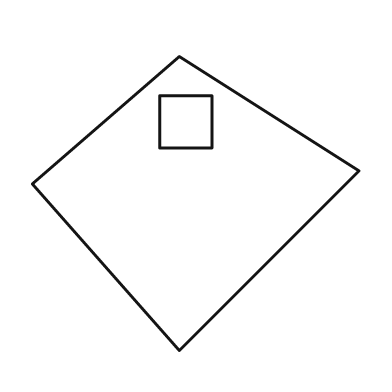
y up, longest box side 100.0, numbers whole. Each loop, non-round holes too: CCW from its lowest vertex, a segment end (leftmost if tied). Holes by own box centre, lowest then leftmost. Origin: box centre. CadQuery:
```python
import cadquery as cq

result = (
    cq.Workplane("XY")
    .moveTo(-5.0, -45.0)
    .lineTo(50.0, 10.0)
    .lineTo(-5.0, 45.0)
    .lineTo(-50.0, 6.0)
    .close()
    .moveTo(-11.0, 17.0)
    .lineTo(5.0, 17.0)
    .lineTo(5.0, 33.0)
    .lineTo(-11.0, 33.0)
    .close()
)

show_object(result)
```